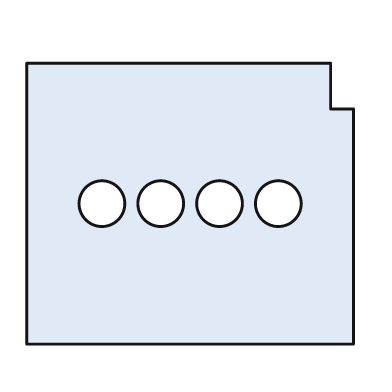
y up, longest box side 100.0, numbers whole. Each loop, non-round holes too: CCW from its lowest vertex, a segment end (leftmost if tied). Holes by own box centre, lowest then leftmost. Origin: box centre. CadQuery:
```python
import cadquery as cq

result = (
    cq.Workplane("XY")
    .moveTo(-50.0, -43.0)
    .lineTo(50.0, -43.0)
    .lineTo(50.0, 29.0)
    .lineTo(43.0, 29.0)
    .lineTo(43.0, 43.0)
    .lineTo(-50.0, 43.0)
    .close()
    .moveTo(-27.0, 0.0)
    .circle(7.0)
    .moveTo(-9.0, 0.0)
    .circle(7.0)
    .moveTo(9.0, 0.0)
    .circle(7.0)
    .moveTo(27.0, 0.0)
    .circle(7.0)
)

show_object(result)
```